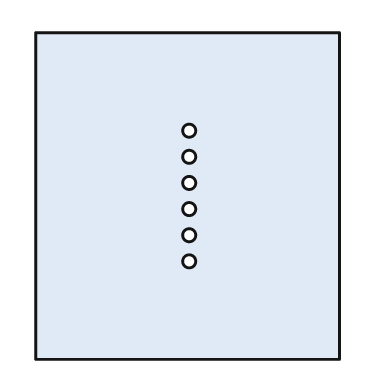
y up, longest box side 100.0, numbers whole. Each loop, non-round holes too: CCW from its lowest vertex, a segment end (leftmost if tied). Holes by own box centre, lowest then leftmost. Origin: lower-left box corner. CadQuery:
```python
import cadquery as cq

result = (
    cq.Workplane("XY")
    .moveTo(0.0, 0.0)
    .lineTo(93.0, 0.0)
    .lineTo(93.0, 100.0)
    .lineTo(0.0, 100.0)
    .close()
    .moveTo(47.0, 30.0)
    .circle(2.0)
    .moveTo(47.0, 38.0)
    .circle(2.0)
    .moveTo(47.0, 46.0)
    .circle(2.0)
    .moveTo(47.0, 54.0)
    .circle(2.0)
    .moveTo(47.0, 62.0)
    .circle(2.0)
    .moveTo(47.0, 70.0)
    .circle(2.0)
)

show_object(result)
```